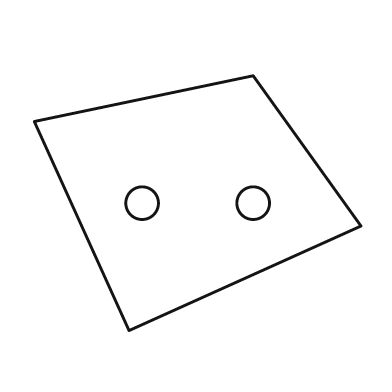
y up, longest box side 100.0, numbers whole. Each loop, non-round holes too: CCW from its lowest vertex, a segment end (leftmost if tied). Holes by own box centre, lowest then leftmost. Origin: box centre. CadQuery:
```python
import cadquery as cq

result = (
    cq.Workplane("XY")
    .moveTo(-21.0, -39.0)
    .lineTo(50.0, -7.0)
    .lineTo(17.0, 39.0)
    .lineTo(-50.0, 25.0)
    .close()
    .moveTo(-17.0, 0.0)
    .circle(5.0)
    .moveTo(17.0, 0.0)
    .circle(5.0)
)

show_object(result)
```